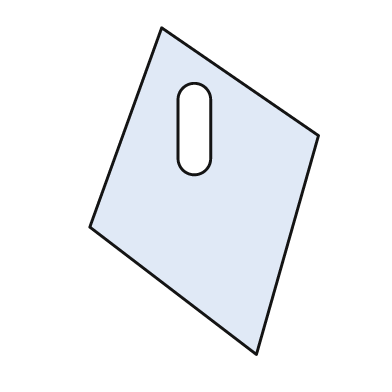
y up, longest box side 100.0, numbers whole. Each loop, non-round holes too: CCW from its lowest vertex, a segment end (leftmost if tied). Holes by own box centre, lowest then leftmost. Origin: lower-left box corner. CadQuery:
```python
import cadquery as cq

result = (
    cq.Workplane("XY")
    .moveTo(51.0, 0.0)
    .lineTo(70.0, 67.0)
    .lineTo(22.0, 100.0)
    .lineTo(0.0, 39.0)
    .close()
    .moveTo(27.0, 60.0)
    .threePointArc((32.0, 55.0), (37.0, 60.0))
    .lineTo(37.0, 78.0)
    .threePointArc((32.0, 83.0), (27.0, 78.0))
    .close()
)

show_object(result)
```